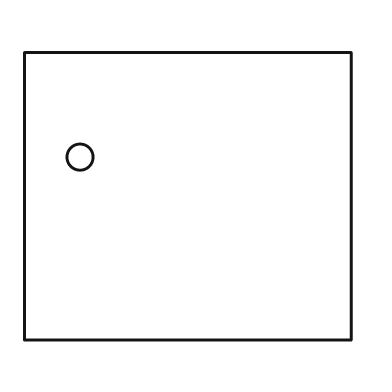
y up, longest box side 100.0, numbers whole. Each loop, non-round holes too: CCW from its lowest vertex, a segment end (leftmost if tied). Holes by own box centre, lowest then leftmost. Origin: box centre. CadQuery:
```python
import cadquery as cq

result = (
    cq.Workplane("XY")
    .moveTo(-50.0, -44.0)
    .lineTo(50.0, -44.0)
    .lineTo(50.0, 44.0)
    .lineTo(-50.0, 44.0)
    .close()
    .moveTo(-33.0, 12.0)
    .circle(4.0)
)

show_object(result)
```